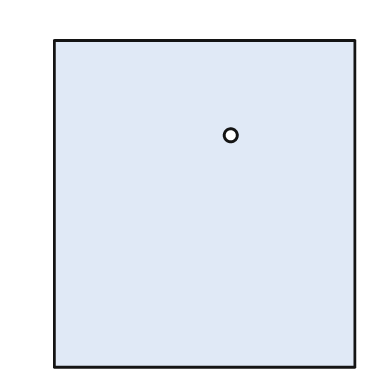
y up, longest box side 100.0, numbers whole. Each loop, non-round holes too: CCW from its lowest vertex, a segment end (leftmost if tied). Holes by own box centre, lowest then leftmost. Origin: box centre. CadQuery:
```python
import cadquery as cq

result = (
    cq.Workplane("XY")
    .moveTo(-46.0, -50.0)
    .lineTo(46.0, -50.0)
    .lineTo(46.0, 50.0)
    .lineTo(-46.0, 50.0)
    .close()
    .moveTo(8.0, 21.0)
    .circle(2.0)
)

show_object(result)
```